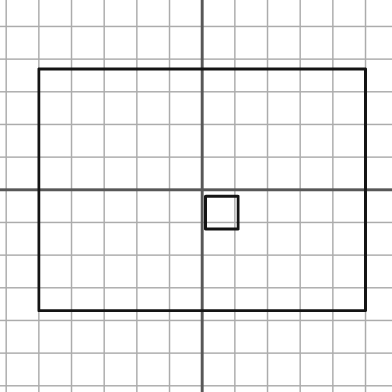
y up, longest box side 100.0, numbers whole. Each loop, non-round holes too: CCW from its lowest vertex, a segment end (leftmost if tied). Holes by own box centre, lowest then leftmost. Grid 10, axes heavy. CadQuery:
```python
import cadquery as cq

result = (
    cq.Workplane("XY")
    .moveTo(-50.0, -37.0)
    .lineTo(50.0, -37.0)
    .lineTo(50.0, 37.0)
    .lineTo(-50.0, 37.0)
    .close()
    .moveTo(1.0, -12.0)
    .lineTo(11.0, -12.0)
    .lineTo(11.0, -2.0)
    .lineTo(1.0, -2.0)
    .close()
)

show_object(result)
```